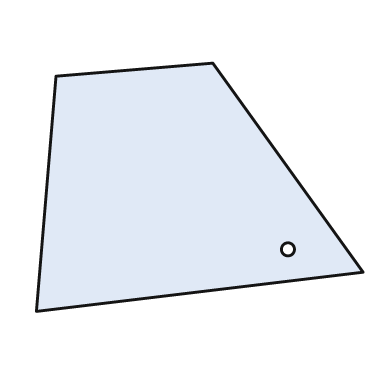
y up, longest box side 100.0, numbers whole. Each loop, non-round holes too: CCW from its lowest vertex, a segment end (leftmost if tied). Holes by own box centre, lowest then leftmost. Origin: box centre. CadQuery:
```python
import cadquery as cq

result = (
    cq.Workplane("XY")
    .moveTo(-50.0, -38.0)
    .lineTo(50.0, -26.0)
    .lineTo(4.0, 38.0)
    .lineTo(-44.0, 34.0)
    .close()
    .moveTo(27.0, -19.0)
    .circle(2.0)
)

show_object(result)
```